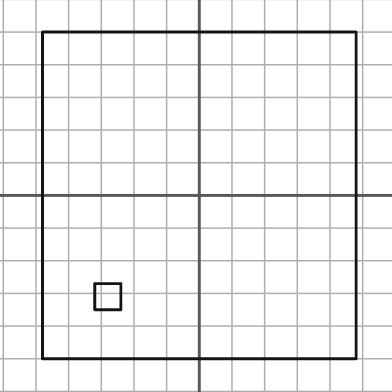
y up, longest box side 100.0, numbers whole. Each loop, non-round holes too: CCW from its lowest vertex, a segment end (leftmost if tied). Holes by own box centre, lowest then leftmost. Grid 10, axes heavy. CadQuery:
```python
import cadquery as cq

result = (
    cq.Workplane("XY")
    .moveTo(-48.0, -50.0)
    .lineTo(48.0, -50.0)
    .lineTo(48.0, 50.0)
    .lineTo(-48.0, 50.0)
    .close()
    .moveTo(-32.0, -35.0)
    .lineTo(-24.0, -35.0)
    .lineTo(-24.0, -27.0)
    .lineTo(-32.0, -27.0)
    .close()
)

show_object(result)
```